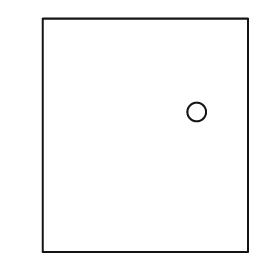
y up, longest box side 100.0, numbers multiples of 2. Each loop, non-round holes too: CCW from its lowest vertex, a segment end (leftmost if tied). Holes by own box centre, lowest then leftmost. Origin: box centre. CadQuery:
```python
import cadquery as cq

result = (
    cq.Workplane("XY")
    .moveTo(-44.0, -50.0)
    .lineTo(44.0, -50.0)
    .lineTo(44.0, 50.0)
    .lineTo(-44.0, 50.0)
    .close()
    .moveTo(22.0, 10.0)
    .circle(4.0)
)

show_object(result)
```